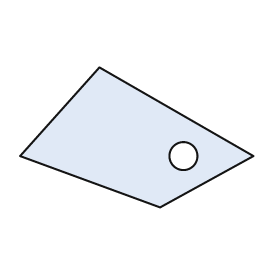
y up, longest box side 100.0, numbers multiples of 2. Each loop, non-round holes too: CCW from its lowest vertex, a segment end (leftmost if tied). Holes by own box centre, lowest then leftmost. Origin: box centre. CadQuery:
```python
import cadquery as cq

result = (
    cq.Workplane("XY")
    .moveTo(10.0, -30.0)
    .lineTo(50.0, -8.0)
    .lineTo(-16.0, 30.0)
    .lineTo(-50.0, -8.0)
    .close()
    .moveTo(20.0, -8.0)
    .circle(6.0)
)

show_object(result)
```